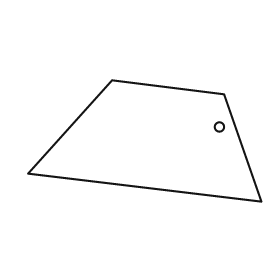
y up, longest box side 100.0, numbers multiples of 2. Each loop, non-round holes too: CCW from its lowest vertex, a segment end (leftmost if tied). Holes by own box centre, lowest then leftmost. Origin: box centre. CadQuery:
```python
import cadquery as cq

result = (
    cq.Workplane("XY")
    .moveTo(50.0, -26.0)
    .lineTo(34.0, 20.0)
    .lineTo(-14.0, 26.0)
    .lineTo(-50.0, -14.0)
    .close()
    .moveTo(32.0, 6.0)
    .circle(2.0)
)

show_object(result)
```